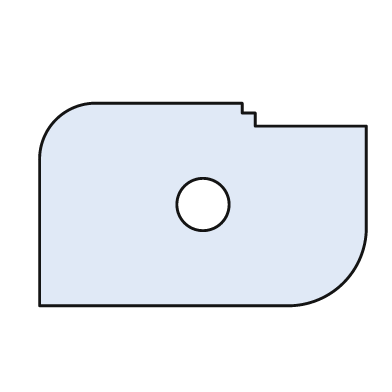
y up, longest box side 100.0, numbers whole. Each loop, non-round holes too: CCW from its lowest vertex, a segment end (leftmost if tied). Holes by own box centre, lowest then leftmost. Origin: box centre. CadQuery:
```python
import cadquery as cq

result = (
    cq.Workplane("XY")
    .moveTo(-50.0, -31.0)
    .lineTo(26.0, -31.0)
    .threePointArc((43.0, -24.0), (50.0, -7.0))
    .lineTo(50.0, 24.0)
    .lineTo(16.0, 24.0)
    .lineTo(16.0, 28.0)
    .lineTo(12.0, 28.0)
    .lineTo(12.0, 31.0)
    .lineTo(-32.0, 31.0)
    .threePointArc((-45.0, 26.0), (-50.0, 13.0))
    .close()
    .moveTo(0.0, 0.0)
    .circle(8.0)
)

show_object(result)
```